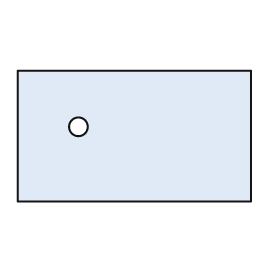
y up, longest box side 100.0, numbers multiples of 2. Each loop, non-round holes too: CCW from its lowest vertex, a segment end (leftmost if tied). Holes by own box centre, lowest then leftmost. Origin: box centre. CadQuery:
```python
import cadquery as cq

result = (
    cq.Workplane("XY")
    .moveTo(-50.0, -28.0)
    .lineTo(50.0, -28.0)
    .lineTo(50.0, 28.0)
    .lineTo(-50.0, 28.0)
    .close()
    .moveTo(-24.0, 4.0)
    .circle(4.0)
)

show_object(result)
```